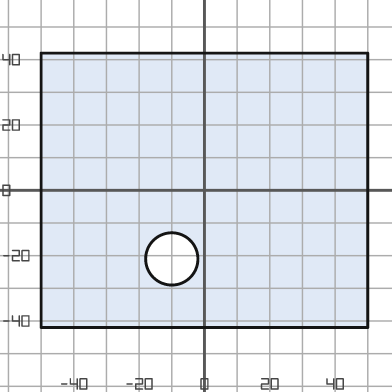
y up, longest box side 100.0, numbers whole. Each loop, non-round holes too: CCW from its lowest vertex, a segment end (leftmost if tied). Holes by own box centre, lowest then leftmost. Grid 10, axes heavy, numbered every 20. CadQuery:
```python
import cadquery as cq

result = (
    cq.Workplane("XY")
    .moveTo(-50.0, -42.0)
    .lineTo(50.0, -42.0)
    .lineTo(50.0, 42.0)
    .lineTo(-50.0, 42.0)
    .close()
    .moveTo(-10.0, -21.0)
    .circle(8.0)
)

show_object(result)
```